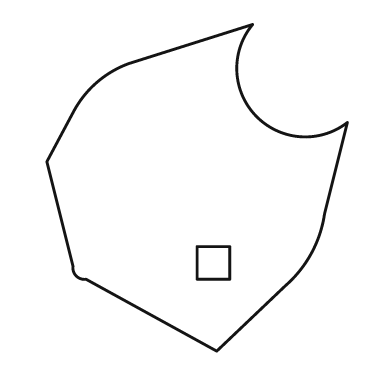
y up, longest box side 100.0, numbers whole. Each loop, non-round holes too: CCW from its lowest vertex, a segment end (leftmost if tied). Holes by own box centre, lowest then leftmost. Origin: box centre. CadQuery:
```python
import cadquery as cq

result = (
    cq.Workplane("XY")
    .moveTo(6.0, -50.0)
    .lineTo(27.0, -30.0)
    .threePointArc((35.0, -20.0), (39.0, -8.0))
    .lineTo(46.0, 20.0)
    .threePointArc((18.0, 22.0), (17.0, 50.0))
    .lineTo(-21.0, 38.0)
    .threePointArc((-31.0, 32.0), (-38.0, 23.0))
    .lineTo(-46.0, 8.0)
    .lineTo(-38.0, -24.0)
    .threePointArc((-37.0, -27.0), (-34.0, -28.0))
    .close()
    .moveTo(0.0, -28.0)
    .lineTo(10.0, -28.0)
    .lineTo(10.0, -18.0)
    .lineTo(0.0, -18.0)
    .close()
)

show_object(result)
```